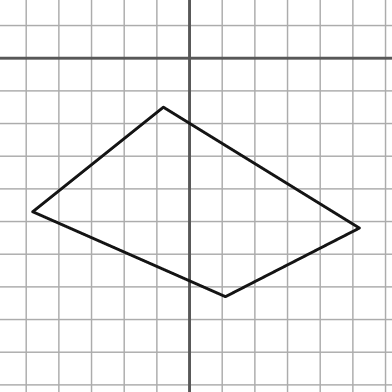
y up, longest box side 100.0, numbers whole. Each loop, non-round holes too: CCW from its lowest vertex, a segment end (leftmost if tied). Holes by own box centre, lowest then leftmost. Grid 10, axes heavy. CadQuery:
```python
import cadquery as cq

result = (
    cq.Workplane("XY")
    .moveTo(11.0, -73.0)
    .lineTo(52.0, -52.0)
    .lineTo(-8.0, -15.0)
    .lineTo(-48.0, -47.0)
    .close()
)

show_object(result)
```